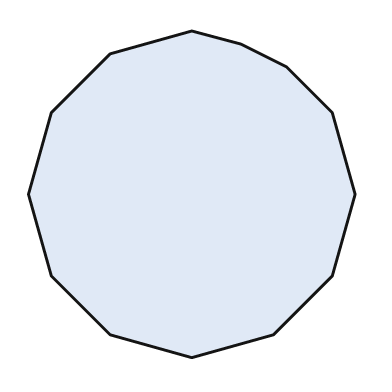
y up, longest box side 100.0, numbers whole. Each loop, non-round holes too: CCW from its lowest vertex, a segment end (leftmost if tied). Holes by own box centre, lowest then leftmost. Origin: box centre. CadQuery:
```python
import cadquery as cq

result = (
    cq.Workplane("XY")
    .moveTo(0.0, -50.0)
    .lineTo(25.0, -43.0)
    .lineTo(43.0, -25.0)
    .lineTo(50.0, 0.0)
    .lineTo(43.0, 25.0)
    .lineTo(29.0, 39.0)
    .lineTo(15.0, 46.0)
    .lineTo(0.0, 50.0)
    .lineTo(-25.0, 43.0)
    .lineTo(-43.0, 25.0)
    .lineTo(-50.0, 0.0)
    .lineTo(-43.0, -25.0)
    .lineTo(-25.0, -43.0)
    .close()
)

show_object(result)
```